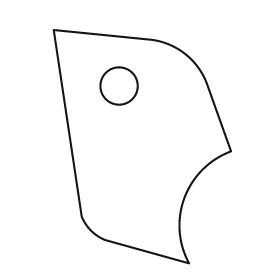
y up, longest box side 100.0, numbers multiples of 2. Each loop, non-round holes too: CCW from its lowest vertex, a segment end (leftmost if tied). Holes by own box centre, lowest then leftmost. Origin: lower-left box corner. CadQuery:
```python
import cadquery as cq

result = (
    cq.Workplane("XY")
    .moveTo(58.0, 0.0)
    .threePointArc((56.0, 28.0), (76.0, 48.0))
    .lineTo(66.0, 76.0)
    .threePointArc((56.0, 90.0), (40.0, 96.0))
    .lineTo(0.0, 100.0)
    .lineTo(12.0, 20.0)
    .threePointArc((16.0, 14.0), (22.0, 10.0))
    .close()
    .moveTo(28.0, 76.0)
    .circle(8.0)
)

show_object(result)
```